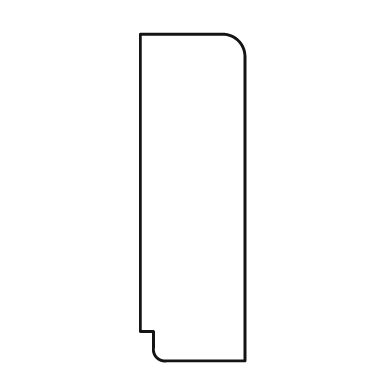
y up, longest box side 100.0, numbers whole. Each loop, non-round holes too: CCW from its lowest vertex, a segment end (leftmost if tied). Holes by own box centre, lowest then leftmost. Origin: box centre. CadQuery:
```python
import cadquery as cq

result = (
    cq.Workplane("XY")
    .moveTo(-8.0, -50.0)
    .lineTo(16.0, -50.0)
    .lineTo(16.0, 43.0)
    .threePointArc((14.0, 48.0), (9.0, 50.0))
    .lineTo(-16.0, 50.0)
    .lineTo(-16.0, -41.0)
    .lineTo(-12.0, -41.0)
    .lineTo(-12.0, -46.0)
    .threePointArc((-11.0, -49.0), (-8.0, -50.0))
    .close()
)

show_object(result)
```